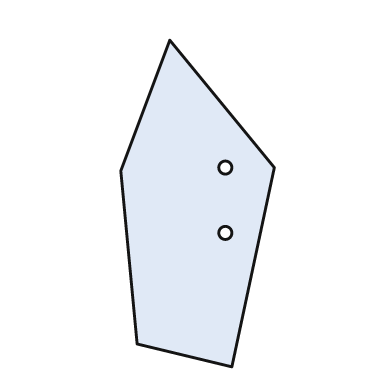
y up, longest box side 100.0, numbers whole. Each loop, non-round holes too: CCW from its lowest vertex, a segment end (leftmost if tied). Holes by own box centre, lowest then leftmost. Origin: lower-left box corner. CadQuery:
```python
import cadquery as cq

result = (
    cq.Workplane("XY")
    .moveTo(34.0, 0.0)
    .lineTo(47.0, 61.0)
    .lineTo(15.0, 100.0)
    .lineTo(0.0, 60.0)
    .lineTo(5.0, 7.0)
    .close()
    .moveTo(32.0, 41.0)
    .circle(2.0)
    .moveTo(32.0, 61.0)
    .circle(2.0)
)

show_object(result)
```